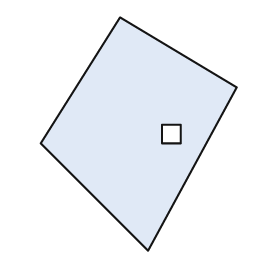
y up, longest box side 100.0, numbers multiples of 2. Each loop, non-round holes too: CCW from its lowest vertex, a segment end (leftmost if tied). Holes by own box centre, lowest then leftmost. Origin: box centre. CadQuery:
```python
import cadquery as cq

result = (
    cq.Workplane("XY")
    .moveTo(4.0, -50.0)
    .lineTo(42.0, 20.0)
    .lineTo(-8.0, 50.0)
    .lineTo(-42.0, -4.0)
    .close()
    .moveTo(10.0, -4.0)
    .lineTo(18.0, -4.0)
    .lineTo(18.0, 4.0)
    .lineTo(10.0, 4.0)
    .close()
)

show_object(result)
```